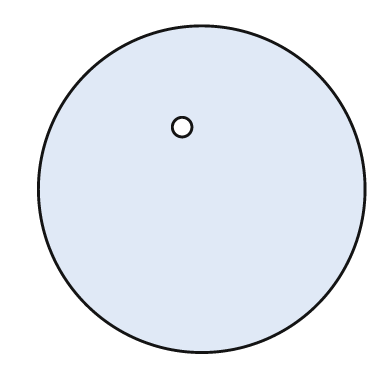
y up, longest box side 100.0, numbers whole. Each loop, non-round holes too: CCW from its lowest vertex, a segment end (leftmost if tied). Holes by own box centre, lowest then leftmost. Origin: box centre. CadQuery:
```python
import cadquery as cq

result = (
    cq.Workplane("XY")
    .moveTo(0.0, 0.0)
    .circle(50.0)
    .moveTo(-6.0, 19.0)
    .circle(3.0)
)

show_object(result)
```